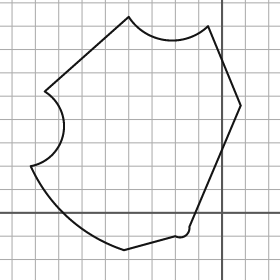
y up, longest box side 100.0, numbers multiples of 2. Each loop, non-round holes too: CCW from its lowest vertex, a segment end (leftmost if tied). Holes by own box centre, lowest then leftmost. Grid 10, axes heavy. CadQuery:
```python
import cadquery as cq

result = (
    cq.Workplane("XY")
    .moveTo(-42.0, -16.0)
    .lineTo(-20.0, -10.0)
    .threePointArc((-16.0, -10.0), (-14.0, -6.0))
    .lineTo(8.0, 46.0)
    .lineTo(-6.0, 80.0)
    .threePointArc((-24.0, 74.0), (-40.0, 84.0))
    .lineTo(-76.0, 52.0)
    .threePointArc((-68.0, 34.0), (-82.0, 20.0))
    .threePointArc((-66.0, -2.0), (-42.0, -16.0))
    .close()
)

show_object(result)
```